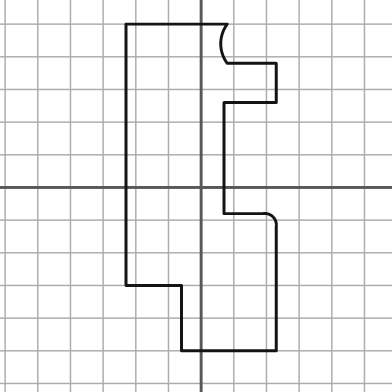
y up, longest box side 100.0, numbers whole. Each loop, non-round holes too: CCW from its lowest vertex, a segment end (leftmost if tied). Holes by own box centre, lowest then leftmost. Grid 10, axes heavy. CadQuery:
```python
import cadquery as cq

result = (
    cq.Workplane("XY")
    .moveTo(-6.0, -50.0)
    .lineTo(23.0, -50.0)
    .lineTo(23.0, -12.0)
    .threePointArc((22.0, -9.0), (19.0, -8.0))
    .lineTo(7.0, -8.0)
    .lineTo(7.0, 26.0)
    .lineTo(23.0, 26.0)
    .lineTo(23.0, 38.0)
    .lineTo(8.0, 38.0)
    .threePointArc((6.0, 44.0), (8.0, 50.0))
    .lineTo(-23.0, 50.0)
    .lineTo(-23.0, -30.0)
    .lineTo(-6.0, -30.0)
    .close()
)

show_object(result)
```